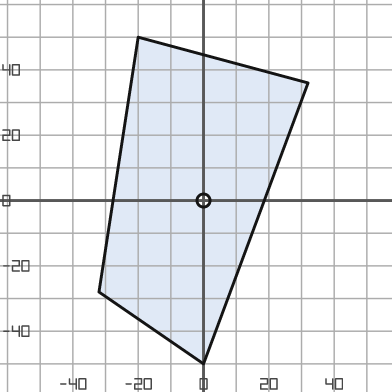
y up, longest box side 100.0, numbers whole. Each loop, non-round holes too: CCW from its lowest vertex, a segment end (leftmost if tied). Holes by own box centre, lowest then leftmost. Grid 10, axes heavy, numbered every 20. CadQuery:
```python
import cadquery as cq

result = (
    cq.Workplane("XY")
    .moveTo(0.0, -50.0)
    .lineTo(32.0, 36.0)
    .lineTo(-20.0, 50.0)
    .lineTo(-32.0, -28.0)
    .close()
    .moveTo(0.0, 0.0)
    .circle(2.0)
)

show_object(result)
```